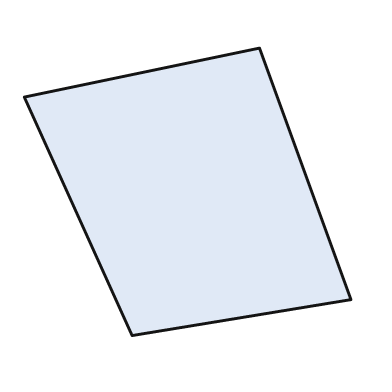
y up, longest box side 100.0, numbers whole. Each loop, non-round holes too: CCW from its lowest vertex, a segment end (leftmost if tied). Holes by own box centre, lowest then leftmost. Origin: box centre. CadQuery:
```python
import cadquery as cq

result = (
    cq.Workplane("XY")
    .moveTo(-17.0, -44.0)
    .lineTo(50.0, -33.0)
    .lineTo(22.0, 44.0)
    .lineTo(-50.0, 29.0)
    .close()
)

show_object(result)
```